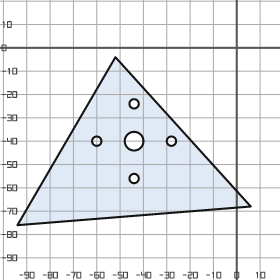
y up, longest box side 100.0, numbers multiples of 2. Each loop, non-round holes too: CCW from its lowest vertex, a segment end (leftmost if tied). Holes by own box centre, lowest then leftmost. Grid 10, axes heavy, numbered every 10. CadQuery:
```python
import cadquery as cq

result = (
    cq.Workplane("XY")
    .moveTo(-94.0, -76.0)
    .lineTo(6.0, -68.0)
    .lineTo(-52.0, -4.0)
    .close()
    .moveTo(-44.0, -56.0)
    .circle(2.0)
    .moveTo(-60.0, -40.0)
    .circle(2.0)
    .moveTo(-44.0, -40.0)
    .circle(4.0)
    .moveTo(-28.0, -40.0)
    .circle(2.0)
    .moveTo(-44.0, -24.0)
    .circle(2.0)
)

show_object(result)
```